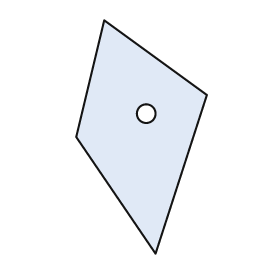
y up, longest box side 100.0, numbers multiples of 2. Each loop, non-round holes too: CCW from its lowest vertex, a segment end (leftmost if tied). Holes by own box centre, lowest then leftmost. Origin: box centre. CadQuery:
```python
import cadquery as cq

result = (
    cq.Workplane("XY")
    .moveTo(6.0, -50.0)
    .lineTo(28.0, 18.0)
    .lineTo(-16.0, 50.0)
    .lineTo(-28.0, 0.0)
    .close()
    .moveTo(2.0, 10.0)
    .circle(4.0)
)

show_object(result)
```